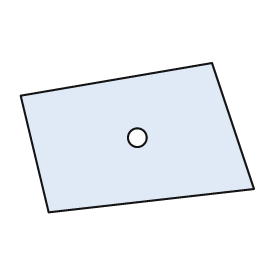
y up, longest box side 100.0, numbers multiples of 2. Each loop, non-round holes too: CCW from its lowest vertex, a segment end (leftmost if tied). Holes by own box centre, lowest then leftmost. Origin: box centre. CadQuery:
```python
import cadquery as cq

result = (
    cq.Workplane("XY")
    .moveTo(-38.0, -32.0)
    .lineTo(50.0, -22.0)
    .lineTo(32.0, 32.0)
    .lineTo(-50.0, 18.0)
    .close()
    .moveTo(0.0, 0.0)
    .circle(4.0)
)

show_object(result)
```